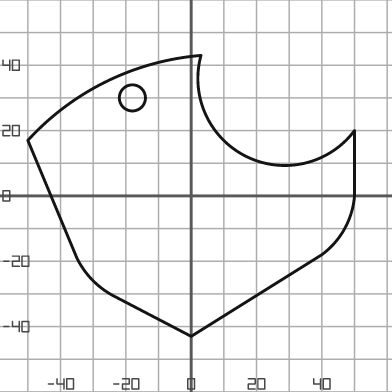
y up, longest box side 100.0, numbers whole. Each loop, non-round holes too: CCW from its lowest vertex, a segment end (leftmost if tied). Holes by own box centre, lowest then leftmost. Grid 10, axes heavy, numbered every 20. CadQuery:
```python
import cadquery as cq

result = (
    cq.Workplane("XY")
    .moveTo(0.0, -43.0)
    .lineTo(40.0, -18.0)
    .threePointArc((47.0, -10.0), (50.0, 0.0))
    .lineTo(50.0, 20.0)
    .threePointArc((17.0, 12.0), (3.0, 43.0))
    .threePointArc((-26.0, 35.0), (-50.0, 17.0))
    .lineTo(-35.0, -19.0)
    .threePointArc((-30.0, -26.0), (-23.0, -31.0))
    .close()
    .moveTo(-18.0, 30.0)
    .circle(4.0)
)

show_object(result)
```